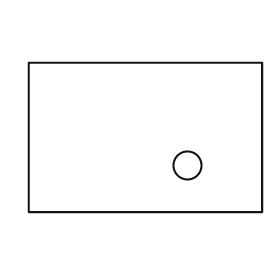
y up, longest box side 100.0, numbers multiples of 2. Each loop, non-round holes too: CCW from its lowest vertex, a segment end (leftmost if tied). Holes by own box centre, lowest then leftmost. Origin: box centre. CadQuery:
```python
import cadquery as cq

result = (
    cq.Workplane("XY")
    .moveTo(-50.0, -32.0)
    .lineTo(50.0, -32.0)
    .lineTo(50.0, 32.0)
    .lineTo(-50.0, 32.0)
    .close()
    .moveTo(18.0, -12.0)
    .circle(6.0)
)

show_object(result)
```